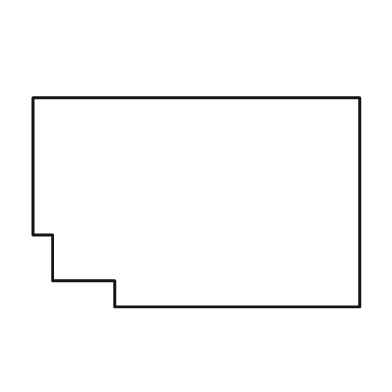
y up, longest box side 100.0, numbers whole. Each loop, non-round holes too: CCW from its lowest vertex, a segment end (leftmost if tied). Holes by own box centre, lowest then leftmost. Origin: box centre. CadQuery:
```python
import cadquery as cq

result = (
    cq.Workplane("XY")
    .moveTo(-25.0, -32.0)
    .lineTo(50.0, -32.0)
    .lineTo(50.0, 32.0)
    .lineTo(-50.0, 32.0)
    .lineTo(-50.0, -10.0)
    .lineTo(-44.0, -10.0)
    .lineTo(-44.0, -24.0)
    .lineTo(-25.0, -24.0)
    .close()
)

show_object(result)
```